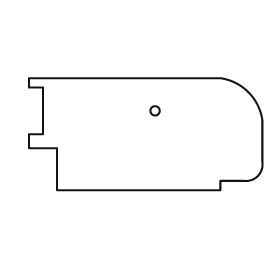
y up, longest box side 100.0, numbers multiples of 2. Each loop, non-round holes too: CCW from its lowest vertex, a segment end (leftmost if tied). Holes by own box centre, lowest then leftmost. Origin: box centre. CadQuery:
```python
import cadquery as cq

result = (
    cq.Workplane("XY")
    .moveTo(-38.0, -24.0)
    .lineTo(32.0, -24.0)
    .lineTo(32.0, -20.0)
    .lineTo(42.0, -20.0)
    .threePointArc((48.0, -18.0), (50.0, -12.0))
    .lineTo(50.0, 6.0)
    .threePointArc((44.0, 18.0), (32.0, 24.0))
    .lineTo(-50.0, 24.0)
    .lineTo(-50.0, 20.0)
    .lineTo(-44.0, 20.0)
    .lineTo(-44.0, 0.0)
    .lineTo(-50.0, 0.0)
    .lineTo(-50.0, -6.0)
    .lineTo(-38.0, -6.0)
    .close()
    .moveTo(4.0, 10.0)
    .circle(2.0)
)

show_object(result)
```